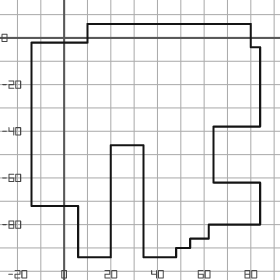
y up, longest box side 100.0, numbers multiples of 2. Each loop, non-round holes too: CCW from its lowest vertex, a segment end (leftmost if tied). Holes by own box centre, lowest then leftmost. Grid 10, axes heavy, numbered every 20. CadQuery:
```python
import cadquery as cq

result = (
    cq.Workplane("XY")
    .moveTo(6.0, -94.0)
    .lineTo(20.0, -94.0)
    .lineTo(20.0, -46.0)
    .lineTo(34.0, -46.0)
    .lineTo(34.0, -94.0)
    .lineTo(48.0, -94.0)
    .lineTo(48.0, -90.0)
    .lineTo(54.0, -90.0)
    .lineTo(54.0, -86.0)
    .lineTo(62.0, -86.0)
    .lineTo(62.0, -80.0)
    .lineTo(84.0, -80.0)
    .lineTo(84.0, -62.0)
    .lineTo(64.0, -62.0)
    .lineTo(64.0, -38.0)
    .lineTo(84.0, -38.0)
    .lineTo(84.0, -4.0)
    .lineTo(80.0, -4.0)
    .lineTo(80.0, 6.0)
    .lineTo(10.0, 6.0)
    .lineTo(10.0, -2.0)
    .lineTo(-14.0, -2.0)
    .lineTo(-14.0, -72.0)
    .lineTo(6.0, -72.0)
    .close()
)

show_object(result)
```